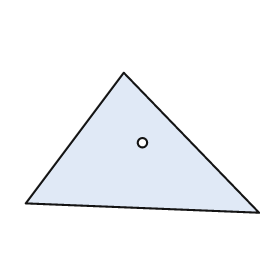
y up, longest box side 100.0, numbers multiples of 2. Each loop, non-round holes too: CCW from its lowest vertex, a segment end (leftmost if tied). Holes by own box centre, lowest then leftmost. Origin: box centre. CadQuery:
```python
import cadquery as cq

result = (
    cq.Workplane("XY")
    .moveTo(50.0, -30.0)
    .lineTo(-8.0, 30.0)
    .lineTo(-50.0, -26.0)
    .close()
    .moveTo(0.0, 0.0)
    .circle(2.0)
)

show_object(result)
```